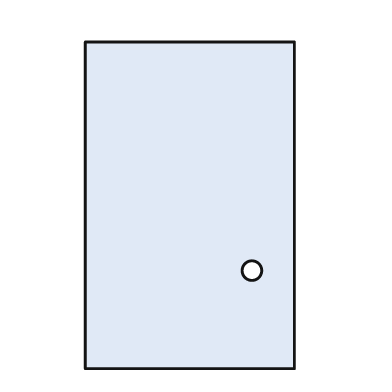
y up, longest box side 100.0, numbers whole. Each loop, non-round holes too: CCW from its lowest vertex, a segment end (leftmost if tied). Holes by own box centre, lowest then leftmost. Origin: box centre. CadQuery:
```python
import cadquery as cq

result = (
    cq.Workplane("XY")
    .moveTo(-32.0, -50.0)
    .lineTo(32.0, -50.0)
    .lineTo(32.0, 50.0)
    .lineTo(-32.0, 50.0)
    .close()
    .moveTo(19.0, -20.0)
    .circle(3.0)
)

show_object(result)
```